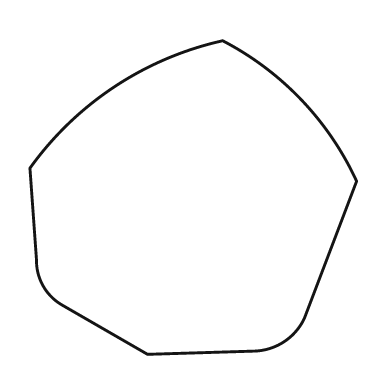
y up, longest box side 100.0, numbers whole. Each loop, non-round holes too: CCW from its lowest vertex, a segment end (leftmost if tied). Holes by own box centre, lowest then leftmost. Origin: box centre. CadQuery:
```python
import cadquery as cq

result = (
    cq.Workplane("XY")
    .moveTo(-14.0, -48.0)
    .lineTo(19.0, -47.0)
    .threePointArc((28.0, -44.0), (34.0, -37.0))
    .lineTo(50.0, 5.0)
    .threePointArc((33.0, 30.0), (9.0, 48.0))
    .threePointArc((-24.0, 34.0), (-50.0, 9.0))
    .lineTo(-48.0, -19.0)
    .threePointArc((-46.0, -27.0), (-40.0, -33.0))
    .close()
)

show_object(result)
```